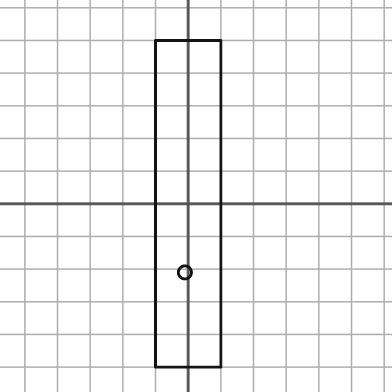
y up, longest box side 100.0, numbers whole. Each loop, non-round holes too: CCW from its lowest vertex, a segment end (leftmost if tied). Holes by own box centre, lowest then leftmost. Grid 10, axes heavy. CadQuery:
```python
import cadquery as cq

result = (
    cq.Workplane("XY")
    .moveTo(-10.0, -50.0)
    .lineTo(10.0, -50.0)
    .lineTo(10.0, 50.0)
    .lineTo(-10.0, 50.0)
    .close()
    .moveTo(-1.0, -21.0)
    .circle(2.0)
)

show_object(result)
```